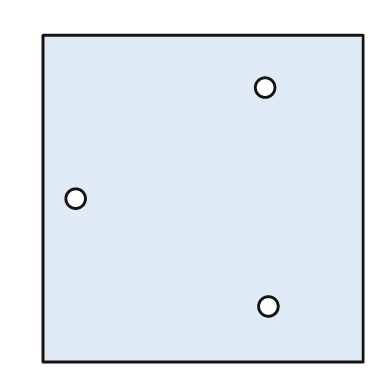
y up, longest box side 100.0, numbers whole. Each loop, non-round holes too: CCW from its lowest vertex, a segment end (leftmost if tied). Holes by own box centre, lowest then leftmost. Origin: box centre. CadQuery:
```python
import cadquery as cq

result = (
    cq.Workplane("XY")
    .moveTo(-49.0, -50.0)
    .lineTo(49.0, -50.0)
    .lineTo(49.0, 50.0)
    .lineTo(-49.0, 50.0)
    .close()
    .moveTo(20.0, -33.0)
    .circle(3.0)
    .moveTo(-39.0, 0.0)
    .circle(3.0)
    .moveTo(19.0, 34.0)
    .circle(3.0)
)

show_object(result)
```